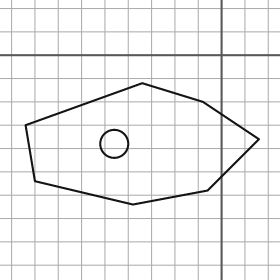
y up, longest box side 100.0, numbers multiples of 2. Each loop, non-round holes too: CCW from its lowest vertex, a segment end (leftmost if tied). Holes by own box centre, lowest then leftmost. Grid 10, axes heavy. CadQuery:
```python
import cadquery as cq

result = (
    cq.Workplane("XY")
    .moveTo(-38.0, -64.0)
    .lineTo(-6.0, -58.0)
    .lineTo(16.0, -36.0)
    .lineTo(-8.0, -20.0)
    .lineTo(-34.0, -12.0)
    .lineTo(-84.0, -30.0)
    .lineTo(-80.0, -54.0)
    .close()
    .moveTo(-46.0, -38.0)
    .circle(6.0)
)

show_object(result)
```